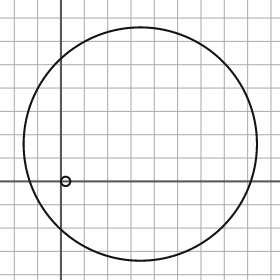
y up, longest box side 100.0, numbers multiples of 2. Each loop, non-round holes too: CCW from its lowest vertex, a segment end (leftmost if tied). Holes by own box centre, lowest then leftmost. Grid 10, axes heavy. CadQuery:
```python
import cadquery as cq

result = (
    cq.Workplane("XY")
    .moveTo(34.0, 16.0)
    .circle(50.0)
    .moveTo(2.0, 0.0)
    .circle(2.0)
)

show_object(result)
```